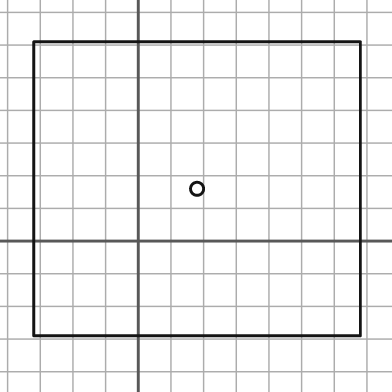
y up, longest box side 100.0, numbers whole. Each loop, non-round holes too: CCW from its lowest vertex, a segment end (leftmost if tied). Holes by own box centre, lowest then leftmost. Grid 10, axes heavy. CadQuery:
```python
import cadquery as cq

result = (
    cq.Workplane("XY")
    .moveTo(-32.0, -29.0)
    .lineTo(68.0, -29.0)
    .lineTo(68.0, 61.0)
    .lineTo(-32.0, 61.0)
    .close()
    .moveTo(18.0, 16.0)
    .circle(2.0)
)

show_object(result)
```